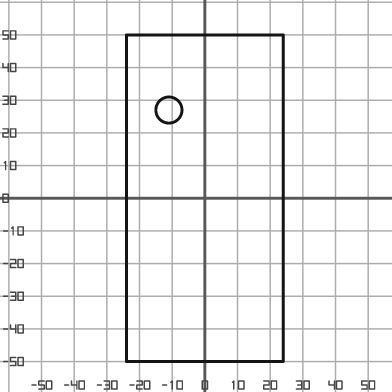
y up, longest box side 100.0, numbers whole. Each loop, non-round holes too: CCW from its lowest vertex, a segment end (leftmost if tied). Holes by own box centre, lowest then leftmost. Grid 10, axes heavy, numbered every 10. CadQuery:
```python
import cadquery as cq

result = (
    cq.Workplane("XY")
    .moveTo(-24.0, -50.0)
    .lineTo(24.0, -50.0)
    .lineTo(24.0, 50.0)
    .lineTo(-24.0, 50.0)
    .close()
    .moveTo(-11.0, 27.0)
    .circle(4.0)
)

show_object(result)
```